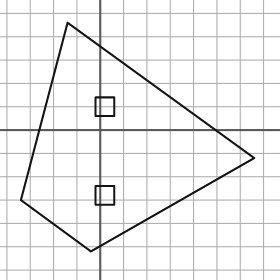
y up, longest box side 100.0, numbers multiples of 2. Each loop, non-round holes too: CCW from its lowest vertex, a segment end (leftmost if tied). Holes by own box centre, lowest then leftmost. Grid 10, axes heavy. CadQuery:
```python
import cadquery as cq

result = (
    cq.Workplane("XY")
    .moveTo(-4.0, -52.0)
    .lineTo(66.0, -12.0)
    .lineTo(-14.0, 46.0)
    .lineTo(-34.0, -30.0)
    .close()
    .moveTo(-2.0, -32.0)
    .lineTo(6.0, -32.0)
    .lineTo(6.0, -24.0)
    .lineTo(-2.0, -24.0)
    .close()
    .moveTo(-2.0, 6.0)
    .lineTo(6.0, 6.0)
    .lineTo(6.0, 14.0)
    .lineTo(-2.0, 14.0)
    .close()
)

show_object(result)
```